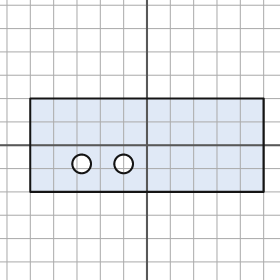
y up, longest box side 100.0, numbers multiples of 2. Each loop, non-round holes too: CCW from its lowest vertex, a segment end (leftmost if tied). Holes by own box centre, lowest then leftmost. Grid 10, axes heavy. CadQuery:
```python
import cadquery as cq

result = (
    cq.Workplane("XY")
    .moveTo(-50.0, -20.0)
    .lineTo(50.0, -20.0)
    .lineTo(50.0, 20.0)
    .lineTo(-50.0, 20.0)
    .close()
    .moveTo(-28.0, -8.0)
    .circle(4.0)
    .moveTo(-10.0, -8.0)
    .circle(4.0)
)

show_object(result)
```